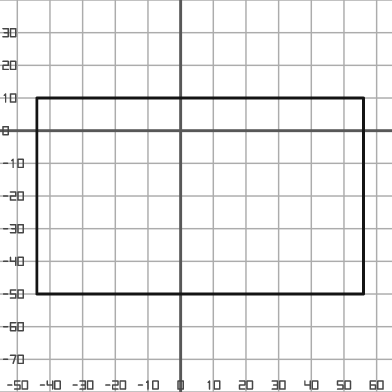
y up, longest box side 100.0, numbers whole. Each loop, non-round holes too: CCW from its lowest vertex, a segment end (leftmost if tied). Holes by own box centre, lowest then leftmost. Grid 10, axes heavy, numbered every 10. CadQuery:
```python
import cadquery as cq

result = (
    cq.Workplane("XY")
    .moveTo(-44.0, -50.0)
    .lineTo(56.0, -50.0)
    .lineTo(56.0, 10.0)
    .lineTo(-44.0, 10.0)
    .close()
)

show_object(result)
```